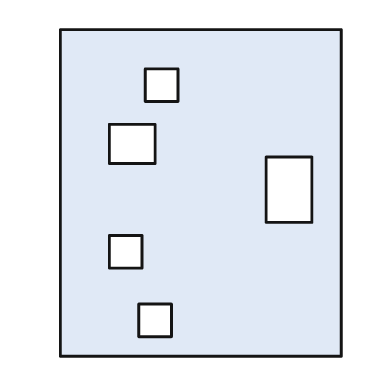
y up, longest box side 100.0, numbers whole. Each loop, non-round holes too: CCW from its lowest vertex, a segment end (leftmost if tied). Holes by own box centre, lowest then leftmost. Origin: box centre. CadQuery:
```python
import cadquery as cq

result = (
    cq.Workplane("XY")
    .moveTo(-43.0, -50.0)
    .lineTo(43.0, -50.0)
    .lineTo(43.0, 50.0)
    .lineTo(-43.0, 50.0)
    .close()
    .moveTo(-19.0, -44.0)
    .lineTo(-9.0, -44.0)
    .lineTo(-9.0, -34.0)
    .lineTo(-19.0, -34.0)
    .close()
    .moveTo(-28.0, -23.0)
    .lineTo(-18.0, -23.0)
    .lineTo(-18.0, -13.0)
    .lineTo(-28.0, -13.0)
    .close()
    .moveTo(20.0, -9.0)
    .lineTo(34.0, -9.0)
    .lineTo(34.0, 11.0)
    .lineTo(20.0, 11.0)
    .close()
    .moveTo(-28.0, 9.0)
    .lineTo(-14.0, 9.0)
    .lineTo(-14.0, 21.0)
    .lineTo(-28.0, 21.0)
    .close()
    .moveTo(-17.0, 28.0)
    .lineTo(-7.0, 28.0)
    .lineTo(-7.0, 38.0)
    .lineTo(-17.0, 38.0)
    .close()
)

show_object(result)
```